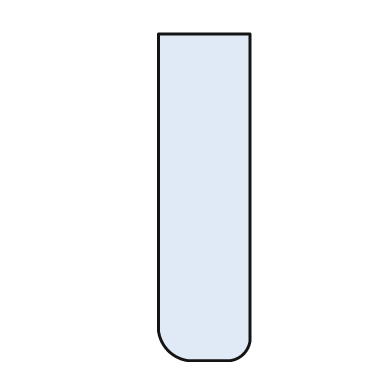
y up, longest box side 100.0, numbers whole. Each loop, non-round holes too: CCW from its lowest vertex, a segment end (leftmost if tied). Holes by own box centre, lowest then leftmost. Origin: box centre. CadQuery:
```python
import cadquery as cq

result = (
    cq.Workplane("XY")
    .moveTo(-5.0, -50.0)
    .lineTo(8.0, -50.0)
    .threePointArc((12.0, -48.0), (14.0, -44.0))
    .lineTo(14.0, 50.0)
    .lineTo(-14.0, 50.0)
    .lineTo(-14.0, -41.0)
    .threePointArc((-11.0, -47.0), (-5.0, -50.0))
    .close()
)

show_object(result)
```